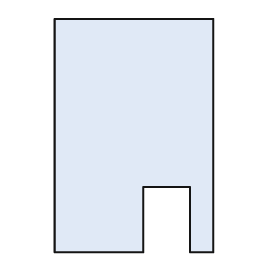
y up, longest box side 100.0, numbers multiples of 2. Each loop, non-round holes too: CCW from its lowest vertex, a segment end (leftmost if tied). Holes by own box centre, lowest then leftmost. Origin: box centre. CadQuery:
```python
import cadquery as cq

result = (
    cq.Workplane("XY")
    .moveTo(-34.0, -50.0)
    .lineTo(4.0, -50.0)
    .lineTo(4.0, -22.0)
    .lineTo(24.0, -22.0)
    .lineTo(24.0, -50.0)
    .lineTo(34.0, -50.0)
    .lineTo(34.0, 50.0)
    .lineTo(-34.0, 50.0)
    .close()
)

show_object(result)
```